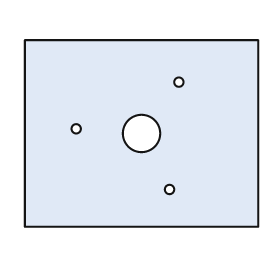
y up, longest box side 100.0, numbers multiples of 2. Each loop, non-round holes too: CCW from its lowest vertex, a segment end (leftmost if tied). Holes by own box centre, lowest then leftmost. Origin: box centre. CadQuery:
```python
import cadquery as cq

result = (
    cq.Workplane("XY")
    .moveTo(-50.0, -40.0)
    .lineTo(50.0, -40.0)
    .lineTo(50.0, 40.0)
    .lineTo(-50.0, 40.0)
    .close()
    .moveTo(12.0, -24.0)
    .circle(2.0)
    .moveTo(0.0, 0.0)
    .circle(8.0)
    .moveTo(-28.0, 2.0)
    .circle(2.0)
    .moveTo(16.0, 22.0)
    .circle(2.0)
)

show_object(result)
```